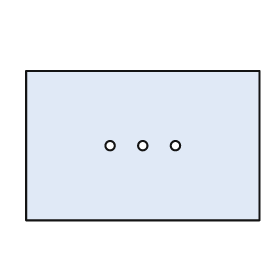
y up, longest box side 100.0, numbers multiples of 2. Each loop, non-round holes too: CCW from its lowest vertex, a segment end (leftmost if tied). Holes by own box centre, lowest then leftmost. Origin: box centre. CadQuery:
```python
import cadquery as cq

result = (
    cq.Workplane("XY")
    .moveTo(-50.0, -32.0)
    .lineTo(50.0, -32.0)
    .lineTo(50.0, 32.0)
    .lineTo(-50.0, 32.0)
    .close()
    .moveTo(-14.0, 0.0)
    .circle(2.0)
    .moveTo(0.0, 0.0)
    .circle(2.0)
    .moveTo(14.0, 0.0)
    .circle(2.0)
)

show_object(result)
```